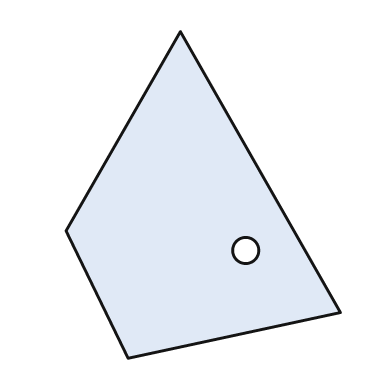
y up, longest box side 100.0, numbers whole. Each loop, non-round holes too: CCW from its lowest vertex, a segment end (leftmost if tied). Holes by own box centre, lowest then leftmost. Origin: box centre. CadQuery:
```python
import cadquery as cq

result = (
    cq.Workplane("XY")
    .moveTo(-23.0, -50.0)
    .lineTo(42.0, -36.0)
    .lineTo(-7.0, 50.0)
    .lineTo(-42.0, -11.0)
    .close()
    .moveTo(13.0, -17.0)
    .circle(4.0)
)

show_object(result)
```